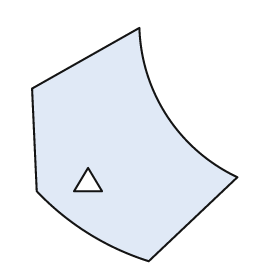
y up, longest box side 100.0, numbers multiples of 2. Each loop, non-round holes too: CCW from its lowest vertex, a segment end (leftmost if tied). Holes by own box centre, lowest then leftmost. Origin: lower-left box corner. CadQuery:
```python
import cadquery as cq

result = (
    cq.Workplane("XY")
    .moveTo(50.0, 0.0)
    .lineTo(88.0, 36.0)
    .threePointArc((58.0, 62.0), (46.0, 100.0))
    .lineTo(0.0, 74.0)
    .lineTo(2.0, 30.0)
    .threePointArc((24.0, 12.0), (50.0, 0.0))
    .close()
    .moveTo(18.0, 30.0)
    .lineTo(30.0, 30.0)
    .lineTo(24.0, 40.0)
    .close()
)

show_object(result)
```